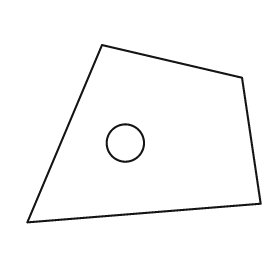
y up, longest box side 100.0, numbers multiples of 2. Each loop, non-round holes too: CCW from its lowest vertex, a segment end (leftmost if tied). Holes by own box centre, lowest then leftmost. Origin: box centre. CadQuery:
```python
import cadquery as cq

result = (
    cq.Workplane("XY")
    .moveTo(-50.0, -38.0)
    .lineTo(50.0, -30.0)
    .lineTo(42.0, 24.0)
    .lineTo(-18.0, 38.0)
    .close()
    .moveTo(-8.0, -4.0)
    .circle(8.0)
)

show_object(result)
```